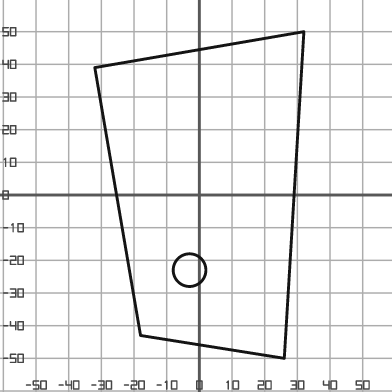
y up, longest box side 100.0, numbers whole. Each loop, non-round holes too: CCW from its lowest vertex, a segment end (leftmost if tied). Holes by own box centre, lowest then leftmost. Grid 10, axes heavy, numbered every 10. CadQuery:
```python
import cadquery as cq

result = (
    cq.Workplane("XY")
    .moveTo(26.0, -50.0)
    .lineTo(32.0, 50.0)
    .lineTo(-32.0, 39.0)
    .lineTo(-18.0, -43.0)
    .close()
    .moveTo(-3.0, -23.0)
    .circle(5.0)
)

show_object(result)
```